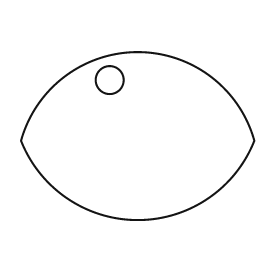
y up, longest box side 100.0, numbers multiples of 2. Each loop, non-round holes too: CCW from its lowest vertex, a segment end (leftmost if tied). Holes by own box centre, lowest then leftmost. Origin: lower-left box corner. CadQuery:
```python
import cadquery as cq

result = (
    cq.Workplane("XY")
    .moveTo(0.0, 34.0)
    .threePointArc((50.0, 0.0), (100.0, 34.0))
    .threePointArc((50.0, 72.0), (0.0, 34.0))
    .close()
    .moveTo(38.0, 60.0)
    .circle(6.0)
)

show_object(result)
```